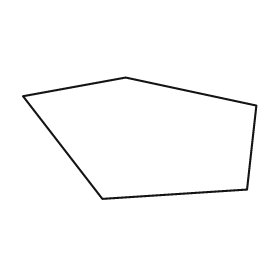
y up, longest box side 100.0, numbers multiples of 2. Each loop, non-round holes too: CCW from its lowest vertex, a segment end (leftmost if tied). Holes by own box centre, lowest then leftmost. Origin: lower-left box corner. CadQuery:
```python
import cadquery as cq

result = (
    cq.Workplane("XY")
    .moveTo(34.0, 0.0)
    .lineTo(96.0, 4.0)
    .lineTo(100.0, 40.0)
    .lineTo(44.0, 52.0)
    .lineTo(0.0, 44.0)
    .close()
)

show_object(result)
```